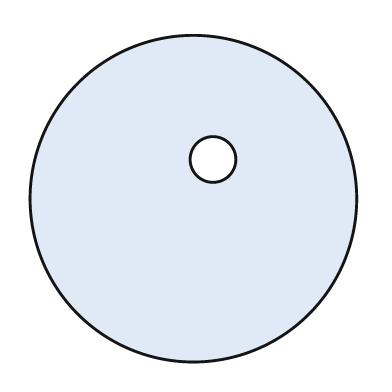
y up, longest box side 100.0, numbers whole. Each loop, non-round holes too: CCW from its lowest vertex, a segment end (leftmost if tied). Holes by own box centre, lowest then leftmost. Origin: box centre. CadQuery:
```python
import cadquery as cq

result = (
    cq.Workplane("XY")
    .moveTo(0.0, 0.0)
    .circle(50.0)
    .moveTo(6.0, 12.0)
    .circle(7.0)
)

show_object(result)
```